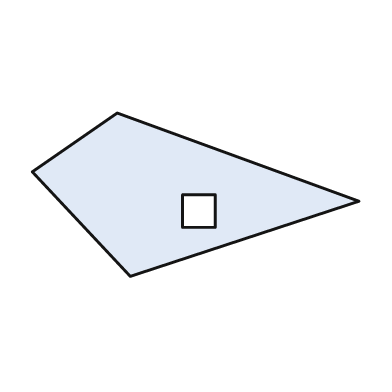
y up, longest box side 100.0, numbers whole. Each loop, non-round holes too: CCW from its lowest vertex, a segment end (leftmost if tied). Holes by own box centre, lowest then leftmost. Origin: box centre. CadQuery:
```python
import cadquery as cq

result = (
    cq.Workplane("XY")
    .moveTo(-20.0, -25.0)
    .lineTo(50.0, -2.0)
    .lineTo(-24.0, 25.0)
    .lineTo(-50.0, 7.0)
    .close()
    .moveTo(-4.0, -10.0)
    .lineTo(6.0, -10.0)
    .lineTo(6.0, 0.0)
    .lineTo(-4.0, 0.0)
    .close()
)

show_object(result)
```